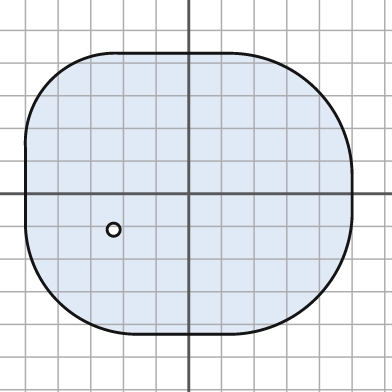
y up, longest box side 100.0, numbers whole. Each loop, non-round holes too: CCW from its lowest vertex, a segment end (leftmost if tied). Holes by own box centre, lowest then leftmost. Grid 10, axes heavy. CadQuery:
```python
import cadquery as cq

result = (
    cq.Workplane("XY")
    .moveTo(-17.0, -43.0)
    .lineTo(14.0, -43.0)
    .threePointArc((39.0, -32.0), (50.0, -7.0))
    .lineTo(50.0, 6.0)
    .threePointArc((39.0, 32.0), (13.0, 43.0))
    .lineTo(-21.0, 43.0)
    .threePointArc((-42.0, 35.0), (-50.0, 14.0))
    .lineTo(-50.0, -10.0)
    .threePointArc((-40.0, -33.0), (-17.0, -43.0))
    .close()
    .moveTo(-23.0, -11.0)
    .circle(2.0)
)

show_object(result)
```